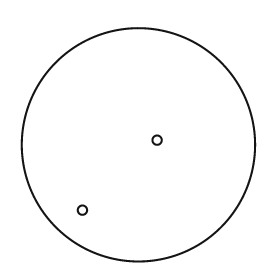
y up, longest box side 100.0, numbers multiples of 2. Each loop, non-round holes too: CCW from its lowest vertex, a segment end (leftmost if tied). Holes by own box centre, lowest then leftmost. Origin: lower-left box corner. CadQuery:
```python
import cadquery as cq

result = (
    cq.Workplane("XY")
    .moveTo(50.0, 50.0)
    .circle(50.0)
    .moveTo(26.0, 22.0)
    .circle(2.0)
    .moveTo(58.0, 52.0)
    .circle(2.0)
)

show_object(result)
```